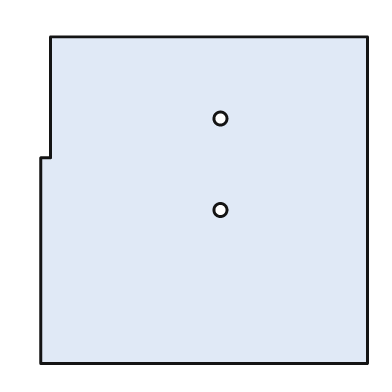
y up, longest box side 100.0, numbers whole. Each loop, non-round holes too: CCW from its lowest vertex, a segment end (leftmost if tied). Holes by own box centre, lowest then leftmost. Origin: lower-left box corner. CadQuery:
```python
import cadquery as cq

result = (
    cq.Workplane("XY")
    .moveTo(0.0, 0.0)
    .lineTo(100.0, 0.0)
    .lineTo(100.0, 100.0)
    .lineTo(3.0, 100.0)
    .lineTo(3.0, 63.0)
    .lineTo(0.0, 63.0)
    .close()
    .moveTo(55.0, 47.0)
    .circle(2.0)
    .moveTo(55.0, 75.0)
    .circle(2.0)
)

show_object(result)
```